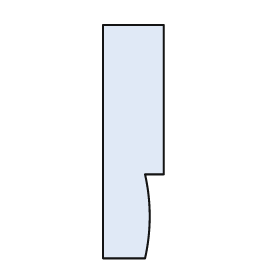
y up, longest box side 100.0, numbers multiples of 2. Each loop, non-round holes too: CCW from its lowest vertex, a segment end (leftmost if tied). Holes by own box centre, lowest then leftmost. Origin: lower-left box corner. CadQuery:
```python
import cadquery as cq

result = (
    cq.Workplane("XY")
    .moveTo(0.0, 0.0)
    .lineTo(18.0, 0.0)
    .threePointArc((20.0, 18.0), (18.0, 36.0))
    .lineTo(26.0, 36.0)
    .lineTo(26.0, 100.0)
    .lineTo(0.0, 100.0)
    .close()
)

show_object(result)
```